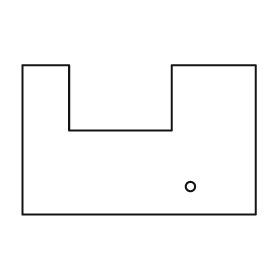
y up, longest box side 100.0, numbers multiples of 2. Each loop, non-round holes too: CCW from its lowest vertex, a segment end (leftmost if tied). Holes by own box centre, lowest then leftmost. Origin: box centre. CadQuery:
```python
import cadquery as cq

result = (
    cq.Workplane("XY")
    .moveTo(-50.0, -32.0)
    .lineTo(50.0, -32.0)
    .lineTo(50.0, 32.0)
    .lineTo(14.0, 32.0)
    .lineTo(14.0, 4.0)
    .lineTo(-30.0, 4.0)
    .lineTo(-30.0, 32.0)
    .lineTo(-50.0, 32.0)
    .close()
    .moveTo(22.0, -20.0)
    .circle(2.0)
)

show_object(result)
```